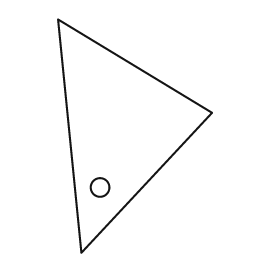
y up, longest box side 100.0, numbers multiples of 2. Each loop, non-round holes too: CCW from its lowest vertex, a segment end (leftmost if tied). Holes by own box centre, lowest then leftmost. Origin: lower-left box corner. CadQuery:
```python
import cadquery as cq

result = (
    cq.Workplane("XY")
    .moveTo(10.0, 0.0)
    .lineTo(66.0, 60.0)
    .lineTo(0.0, 100.0)
    .close()
    .moveTo(18.0, 28.0)
    .circle(4.0)
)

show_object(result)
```